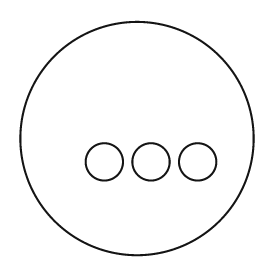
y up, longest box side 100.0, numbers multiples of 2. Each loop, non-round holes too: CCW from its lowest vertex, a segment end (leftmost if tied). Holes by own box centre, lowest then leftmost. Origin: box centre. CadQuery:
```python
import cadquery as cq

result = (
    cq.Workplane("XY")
    .moveTo(0.0, 0.0)
    .circle(50.0)
    .moveTo(-14.0, -10.0)
    .circle(8.0)
    .moveTo(6.0, -10.0)
    .circle(8.0)
    .moveTo(26.0, -10.0)
    .circle(8.0)
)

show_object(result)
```